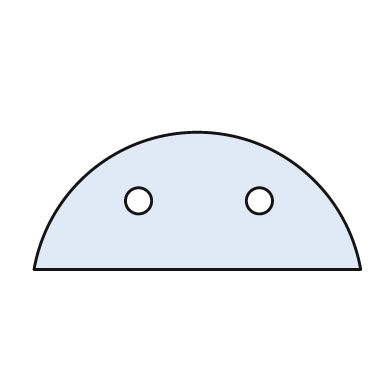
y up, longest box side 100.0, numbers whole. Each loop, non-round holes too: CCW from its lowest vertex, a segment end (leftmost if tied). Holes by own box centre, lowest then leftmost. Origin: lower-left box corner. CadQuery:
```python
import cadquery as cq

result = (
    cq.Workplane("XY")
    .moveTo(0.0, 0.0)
    .lineTo(100.0, 0.0)
    .threePointArc((50.0, 42.0), (0.0, 0.0))
    .close()
    .moveTo(32.0, 21.0)
    .circle(4.0)
    .moveTo(69.0, 21.0)
    .circle(4.0)
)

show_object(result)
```